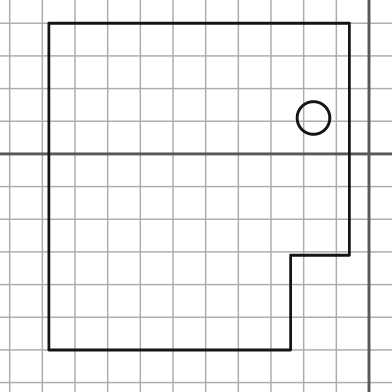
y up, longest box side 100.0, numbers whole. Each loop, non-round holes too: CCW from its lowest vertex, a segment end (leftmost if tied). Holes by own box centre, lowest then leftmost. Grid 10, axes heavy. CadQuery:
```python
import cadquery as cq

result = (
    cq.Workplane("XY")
    .moveTo(-98.0, -60.0)
    .lineTo(-24.0, -60.0)
    .lineTo(-24.0, -31.0)
    .lineTo(-6.0, -31.0)
    .lineTo(-6.0, 40.0)
    .lineTo(-98.0, 40.0)
    .close()
    .moveTo(-17.0, 11.0)
    .circle(5.0)
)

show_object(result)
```